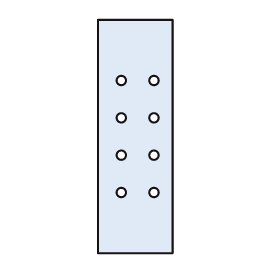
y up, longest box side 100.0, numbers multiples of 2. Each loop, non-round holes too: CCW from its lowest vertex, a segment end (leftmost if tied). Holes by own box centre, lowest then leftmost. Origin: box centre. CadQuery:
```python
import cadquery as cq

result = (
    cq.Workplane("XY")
    .moveTo(-16.0, -50.0)
    .lineTo(16.0, -50.0)
    .lineTo(16.0, 50.0)
    .lineTo(-16.0, 50.0)
    .close()
    .moveTo(-6.0, -24.0)
    .circle(2.0)
    .moveTo(8.0, -24.0)
    .circle(2.0)
    .moveTo(-6.0, -8.0)
    .circle(2.0)
    .moveTo(8.0, -8.0)
    .circle(2.0)
    .moveTo(-6.0, 8.0)
    .circle(2.0)
    .moveTo(8.0, 8.0)
    .circle(2.0)
    .moveTo(-6.0, 24.0)
    .circle(2.0)
    .moveTo(8.0, 24.0)
    .circle(2.0)
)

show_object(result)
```